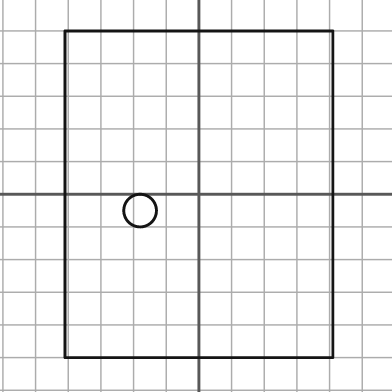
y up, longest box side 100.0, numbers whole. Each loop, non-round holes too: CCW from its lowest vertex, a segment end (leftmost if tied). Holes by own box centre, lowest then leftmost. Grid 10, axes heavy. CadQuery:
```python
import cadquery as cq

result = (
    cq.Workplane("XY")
    .moveTo(-41.0, -50.0)
    .lineTo(41.0, -50.0)
    .lineTo(41.0, 50.0)
    .lineTo(-41.0, 50.0)
    .close()
    .moveTo(-18.0, -5.0)
    .circle(5.0)
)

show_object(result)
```